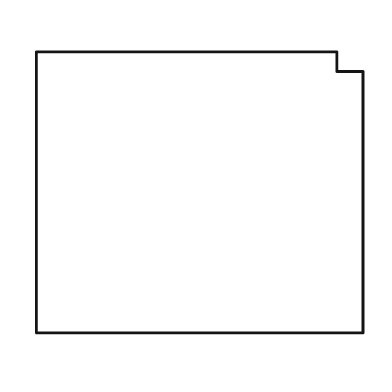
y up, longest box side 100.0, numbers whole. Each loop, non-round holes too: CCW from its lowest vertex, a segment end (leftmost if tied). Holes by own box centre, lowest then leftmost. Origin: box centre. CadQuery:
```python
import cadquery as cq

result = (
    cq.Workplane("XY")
    .moveTo(-50.0, -43.0)
    .lineTo(50.0, -43.0)
    .lineTo(50.0, 37.0)
    .lineTo(42.0, 37.0)
    .lineTo(42.0, 43.0)
    .lineTo(-50.0, 43.0)
    .close()
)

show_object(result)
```